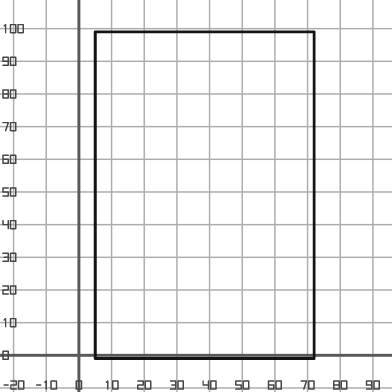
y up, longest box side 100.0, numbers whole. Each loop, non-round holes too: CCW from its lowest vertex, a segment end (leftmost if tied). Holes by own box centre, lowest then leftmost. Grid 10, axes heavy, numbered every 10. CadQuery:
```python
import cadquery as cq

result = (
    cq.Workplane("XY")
    .moveTo(5.0, -1.0)
    .lineTo(72.0, -1.0)
    .lineTo(72.0, 99.0)
    .lineTo(5.0, 99.0)
    .close()
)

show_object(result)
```